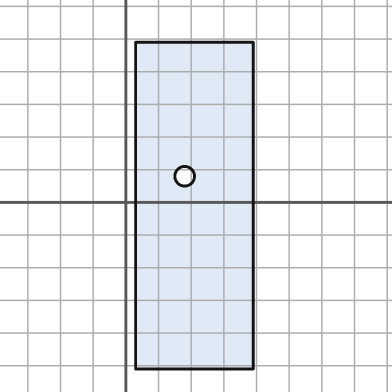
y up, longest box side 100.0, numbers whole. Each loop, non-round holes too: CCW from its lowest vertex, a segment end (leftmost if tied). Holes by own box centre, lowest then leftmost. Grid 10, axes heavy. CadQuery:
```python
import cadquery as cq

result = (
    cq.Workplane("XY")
    .moveTo(3.0, -51.0)
    .lineTo(39.0, -51.0)
    .lineTo(39.0, 49.0)
    .lineTo(3.0, 49.0)
    .close()
    .moveTo(18.0, 8.0)
    .circle(3.0)
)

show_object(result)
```